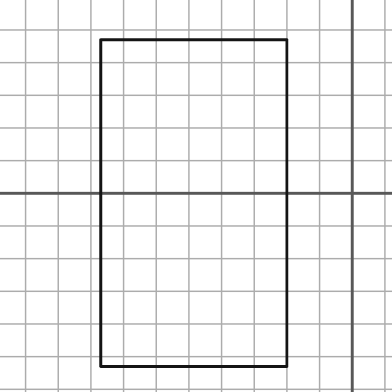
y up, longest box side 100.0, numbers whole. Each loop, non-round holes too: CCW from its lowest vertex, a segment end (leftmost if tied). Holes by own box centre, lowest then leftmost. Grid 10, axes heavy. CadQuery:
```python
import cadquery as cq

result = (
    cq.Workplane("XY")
    .moveTo(-77.0, -53.0)
    .lineTo(-20.0, -53.0)
    .lineTo(-20.0, 47.0)
    .lineTo(-77.0, 47.0)
    .close()
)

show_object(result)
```